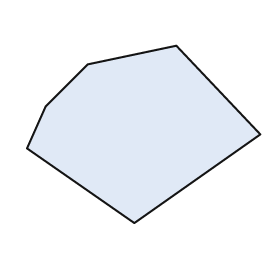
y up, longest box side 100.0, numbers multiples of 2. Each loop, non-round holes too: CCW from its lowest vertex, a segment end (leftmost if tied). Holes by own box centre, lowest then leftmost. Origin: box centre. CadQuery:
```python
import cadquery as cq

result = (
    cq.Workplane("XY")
    .moveTo(-4.0, -38.0)
    .lineTo(50.0, 0.0)
    .lineTo(14.0, 38.0)
    .lineTo(-24.0, 30.0)
    .lineTo(-42.0, 12.0)
    .lineTo(-50.0, -6.0)
    .close()
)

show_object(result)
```